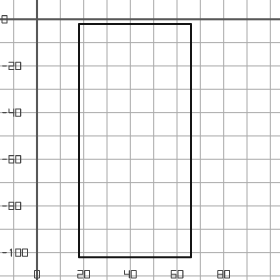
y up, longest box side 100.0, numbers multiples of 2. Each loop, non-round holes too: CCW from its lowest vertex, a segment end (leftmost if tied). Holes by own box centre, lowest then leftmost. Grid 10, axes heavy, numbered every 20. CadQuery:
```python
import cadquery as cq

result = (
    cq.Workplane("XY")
    .moveTo(18.0, -102.0)
    .lineTo(66.0, -102.0)
    .lineTo(66.0, -2.0)
    .lineTo(18.0, -2.0)
    .close()
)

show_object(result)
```